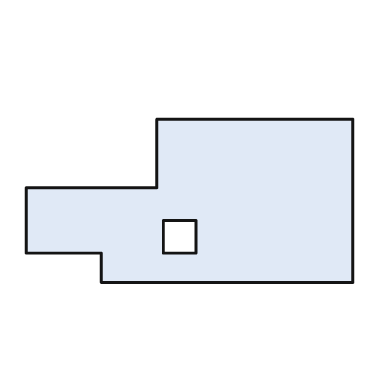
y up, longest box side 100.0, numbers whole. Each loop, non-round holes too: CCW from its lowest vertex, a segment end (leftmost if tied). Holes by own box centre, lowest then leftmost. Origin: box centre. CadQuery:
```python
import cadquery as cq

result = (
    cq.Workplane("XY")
    .moveTo(-27.0, -25.0)
    .lineTo(50.0, -25.0)
    .lineTo(50.0, 25.0)
    .lineTo(-10.0, 25.0)
    .lineTo(-10.0, 4.0)
    .lineTo(-50.0, 4.0)
    .lineTo(-50.0, -16.0)
    .lineTo(-27.0, -16.0)
    .close()
    .moveTo(-8.0, -16.0)
    .lineTo(2.0, -16.0)
    .lineTo(2.0, -6.0)
    .lineTo(-8.0, -6.0)
    .close()
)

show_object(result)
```